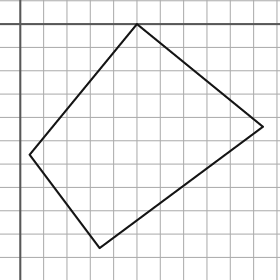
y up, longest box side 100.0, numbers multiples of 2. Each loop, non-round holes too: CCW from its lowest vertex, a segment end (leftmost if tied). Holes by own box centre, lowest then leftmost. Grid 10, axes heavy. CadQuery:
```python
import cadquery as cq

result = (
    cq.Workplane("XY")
    .moveTo(34.0, -96.0)
    .lineTo(104.0, -44.0)
    .lineTo(50.0, 0.0)
    .lineTo(4.0, -56.0)
    .close()
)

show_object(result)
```